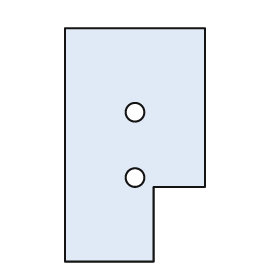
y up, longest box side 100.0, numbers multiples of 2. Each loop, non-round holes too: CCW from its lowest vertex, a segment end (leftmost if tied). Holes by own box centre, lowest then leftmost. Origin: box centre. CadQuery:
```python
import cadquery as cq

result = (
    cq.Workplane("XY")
    .moveTo(-30.0, -50.0)
    .lineTo(8.0, -50.0)
    .lineTo(8.0, -18.0)
    .lineTo(30.0, -18.0)
    .lineTo(30.0, 50.0)
    .lineTo(-30.0, 50.0)
    .close()
    .moveTo(0.0, -14.0)
    .circle(4.0)
    .moveTo(0.0, 14.0)
    .circle(4.0)
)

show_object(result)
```